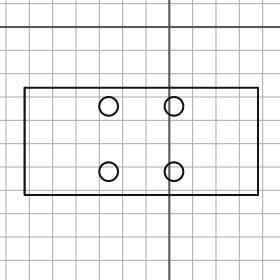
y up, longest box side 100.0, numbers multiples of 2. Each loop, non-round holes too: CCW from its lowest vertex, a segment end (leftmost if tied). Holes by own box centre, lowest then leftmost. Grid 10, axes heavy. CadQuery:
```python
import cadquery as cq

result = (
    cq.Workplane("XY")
    .moveTo(-62.0, -72.0)
    .lineTo(38.0, -72.0)
    .lineTo(38.0, -26.0)
    .lineTo(-62.0, -26.0)
    .close()
    .moveTo(-26.0, -62.0)
    .circle(4.0)
    .moveTo(2.0, -62.0)
    .circle(4.0)
    .moveTo(-26.0, -34.0)
    .circle(4.0)
    .moveTo(2.0, -34.0)
    .circle(4.0)
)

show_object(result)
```